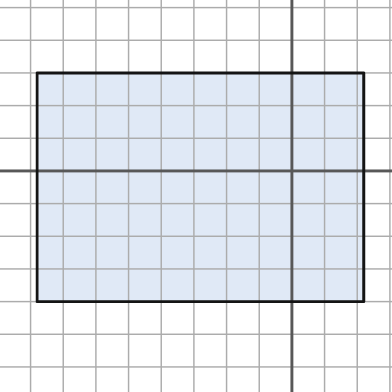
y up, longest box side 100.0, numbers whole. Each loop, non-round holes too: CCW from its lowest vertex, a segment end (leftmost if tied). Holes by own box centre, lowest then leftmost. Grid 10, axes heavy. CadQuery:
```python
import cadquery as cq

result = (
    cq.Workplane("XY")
    .moveTo(-78.0, -40.0)
    .lineTo(22.0, -40.0)
    .lineTo(22.0, 30.0)
    .lineTo(-78.0, 30.0)
    .close()
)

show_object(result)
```